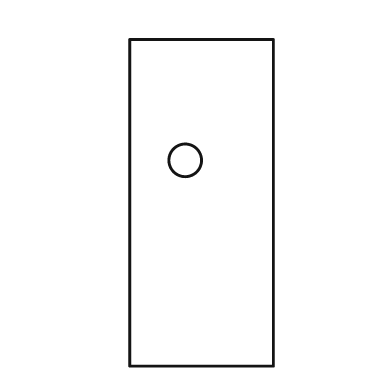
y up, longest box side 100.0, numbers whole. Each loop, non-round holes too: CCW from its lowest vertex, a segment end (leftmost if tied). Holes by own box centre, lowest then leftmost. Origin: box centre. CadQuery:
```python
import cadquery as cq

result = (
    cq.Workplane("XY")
    .moveTo(-22.0, -50.0)
    .lineTo(22.0, -50.0)
    .lineTo(22.0, 50.0)
    .lineTo(-22.0, 50.0)
    .close()
    .moveTo(-5.0, 13.0)
    .circle(5.0)
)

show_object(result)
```